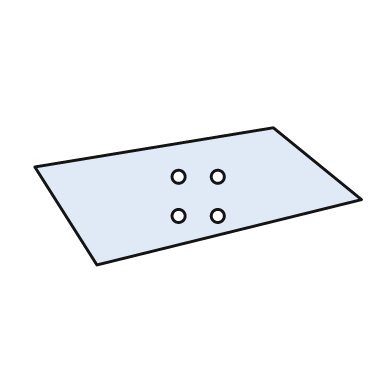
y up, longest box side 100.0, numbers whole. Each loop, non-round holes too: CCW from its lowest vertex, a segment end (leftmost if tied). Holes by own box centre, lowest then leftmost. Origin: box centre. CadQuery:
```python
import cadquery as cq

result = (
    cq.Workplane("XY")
    .moveTo(-31.0, -21.0)
    .lineTo(50.0, -1.0)
    .lineTo(23.0, 21.0)
    .lineTo(-50.0, 9.0)
    .close()
    .moveTo(-6.0, -6.0)
    .circle(2.0)
    .moveTo(6.0, -6.0)
    .circle(2.0)
    .moveTo(-6.0, 6.0)
    .circle(2.0)
    .moveTo(6.0, 6.0)
    .circle(2.0)
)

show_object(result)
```